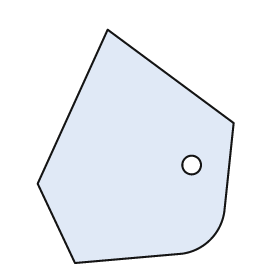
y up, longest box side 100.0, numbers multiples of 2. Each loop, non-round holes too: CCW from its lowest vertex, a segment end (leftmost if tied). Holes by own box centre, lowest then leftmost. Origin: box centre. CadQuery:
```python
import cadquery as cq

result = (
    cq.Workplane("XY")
    .moveTo(-26.0, -50.0)
    .lineTo(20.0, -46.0)
    .threePointArc((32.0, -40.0), (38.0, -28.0))
    .lineTo(42.0, 10.0)
    .lineTo(-12.0, 50.0)
    .lineTo(-42.0, -16.0)
    .close()
    .moveTo(24.0, -8.0)
    .circle(4.0)
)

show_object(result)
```